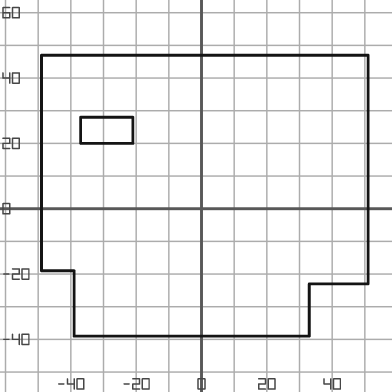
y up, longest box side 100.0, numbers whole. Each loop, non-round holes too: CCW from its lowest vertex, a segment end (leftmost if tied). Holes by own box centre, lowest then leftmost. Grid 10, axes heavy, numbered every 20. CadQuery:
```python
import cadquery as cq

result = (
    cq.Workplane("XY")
    .moveTo(-39.0, -39.0)
    .lineTo(33.0, -39.0)
    .lineTo(33.0, -23.0)
    .lineTo(51.0, -23.0)
    .lineTo(51.0, 47.0)
    .lineTo(-49.0, 47.0)
    .lineTo(-49.0, -19.0)
    .lineTo(-39.0, -19.0)
    .close()
    .moveTo(-37.0, 20.0)
    .lineTo(-21.0, 20.0)
    .lineTo(-21.0, 28.0)
    .lineTo(-37.0, 28.0)
    .close()
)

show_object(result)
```